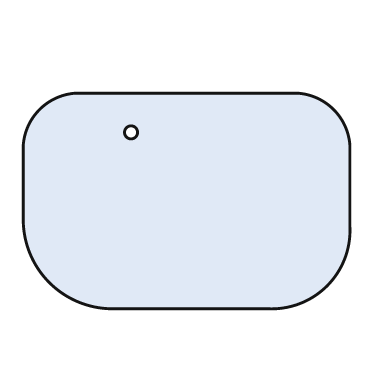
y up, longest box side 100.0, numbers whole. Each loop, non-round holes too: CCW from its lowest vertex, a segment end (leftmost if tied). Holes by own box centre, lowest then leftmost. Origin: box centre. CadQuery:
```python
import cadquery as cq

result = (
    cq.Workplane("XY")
    .moveTo(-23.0, -33.0)
    .lineTo(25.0, -33.0)
    .threePointArc((43.0, -26.0), (50.0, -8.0))
    .lineTo(50.0, 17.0)
    .threePointArc((45.0, 28.0), (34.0, 33.0))
    .lineTo(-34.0, 33.0)
    .threePointArc((-45.0, 28.0), (-50.0, 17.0))
    .lineTo(-50.0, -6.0)
    .threePointArc((-42.0, -25.0), (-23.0, -33.0))
    .close()
    .moveTo(-17.0, 21.0)
    .circle(2.0)
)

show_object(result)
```